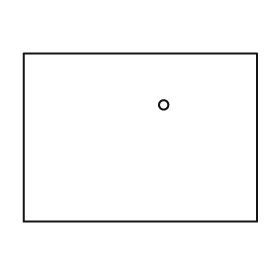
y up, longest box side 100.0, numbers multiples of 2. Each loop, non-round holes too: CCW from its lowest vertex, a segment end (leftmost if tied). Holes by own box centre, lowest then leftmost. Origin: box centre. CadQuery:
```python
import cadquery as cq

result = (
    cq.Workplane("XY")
    .moveTo(-50.0, -36.0)
    .lineTo(50.0, -36.0)
    .lineTo(50.0, 36.0)
    .lineTo(-50.0, 36.0)
    .close()
    .moveTo(10.0, 14.0)
    .circle(2.0)
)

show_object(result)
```